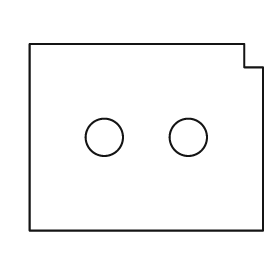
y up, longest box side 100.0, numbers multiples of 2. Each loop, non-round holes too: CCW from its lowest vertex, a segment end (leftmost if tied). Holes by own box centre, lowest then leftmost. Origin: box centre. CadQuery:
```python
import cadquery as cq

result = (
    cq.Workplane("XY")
    .moveTo(-50.0, -40.0)
    .lineTo(50.0, -40.0)
    .lineTo(50.0, 30.0)
    .lineTo(42.0, 30.0)
    .lineTo(42.0, 40.0)
    .lineTo(-50.0, 40.0)
    .close()
    .moveTo(-18.0, 0.0)
    .circle(8.0)
    .moveTo(18.0, 0.0)
    .circle(8.0)
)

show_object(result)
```